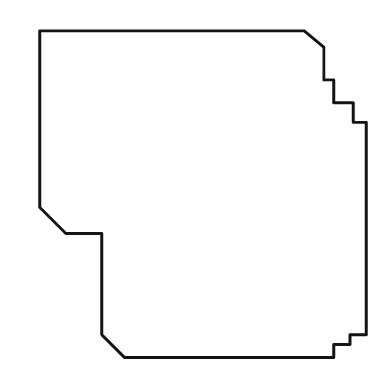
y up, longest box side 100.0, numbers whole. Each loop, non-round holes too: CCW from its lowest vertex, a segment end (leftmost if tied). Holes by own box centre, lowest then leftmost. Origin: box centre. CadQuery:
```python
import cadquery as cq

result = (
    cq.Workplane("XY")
    .moveTo(-24.0, -50.0)
    .lineTo(40.0, -50.0)
    .lineTo(40.0, -46.0)
    .lineTo(45.0, -46.0)
    .lineTo(45.0, -43.0)
    .lineTo(50.0, -43.0)
    .lineTo(50.0, 22.0)
    .lineTo(46.0, 22.0)
    .lineTo(46.0, 28.0)
    .lineTo(40.0, 28.0)
    .lineTo(40.0, 35.0)
    .lineTo(37.0, 35.0)
    .lineTo(37.0, 45.0)
    .lineTo(31.0, 50.0)
    .lineTo(-50.0, 50.0)
    .lineTo(-50.0, -4.0)
    .lineTo(-42.0, -12.0)
    .lineTo(-31.0, -12.0)
    .lineTo(-31.0, -43.0)
    .close()
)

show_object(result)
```